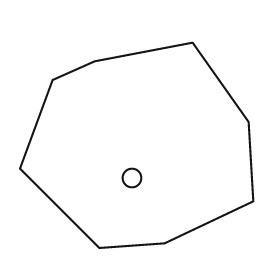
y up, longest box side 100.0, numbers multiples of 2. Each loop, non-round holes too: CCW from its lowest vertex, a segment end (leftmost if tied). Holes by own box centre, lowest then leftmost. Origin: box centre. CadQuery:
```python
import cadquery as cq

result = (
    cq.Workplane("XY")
    .moveTo(-16.0, -44.0)
    .lineTo(12.0, -42.0)
    .lineTo(50.0, -24.0)
    .lineTo(48.0, 10.0)
    .lineTo(24.0, 44.0)
    .lineTo(-18.0, 36.0)
    .lineTo(-36.0, 28.0)
    .lineTo(-50.0, -10.0)
    .close()
    .moveTo(-2.0, -14.0)
    .circle(4.0)
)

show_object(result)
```